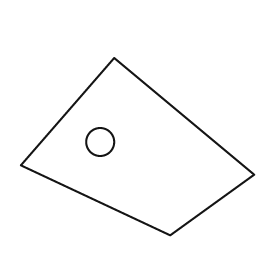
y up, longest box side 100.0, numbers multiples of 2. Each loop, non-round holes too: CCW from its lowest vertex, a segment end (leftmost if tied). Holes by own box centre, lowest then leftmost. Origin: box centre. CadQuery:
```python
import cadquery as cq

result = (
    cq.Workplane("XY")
    .moveTo(14.0, -38.0)
    .lineTo(50.0, -12.0)
    .lineTo(-10.0, 38.0)
    .lineTo(-50.0, -8.0)
    .close()
    .moveTo(-16.0, 2.0)
    .circle(6.0)
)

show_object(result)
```